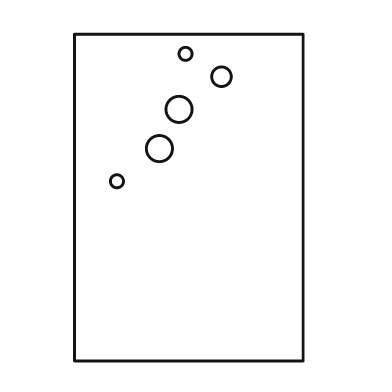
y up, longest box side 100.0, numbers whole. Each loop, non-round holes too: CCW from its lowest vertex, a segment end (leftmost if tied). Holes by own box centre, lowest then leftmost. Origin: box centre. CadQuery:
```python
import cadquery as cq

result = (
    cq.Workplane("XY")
    .moveTo(-35.0, -50.0)
    .lineTo(35.0, -50.0)
    .lineTo(35.0, 50.0)
    .lineTo(-35.0, 50.0)
    .close()
    .moveTo(-22.0, 5.0)
    .circle(2.0)
    .moveTo(-9.0, 15.0)
    .circle(4.0)
    .moveTo(-3.0, 27.0)
    .circle(4.0)
    .moveTo(10.0, 37.0)
    .circle(3.0)
    .moveTo(-1.0, 44.0)
    .circle(2.0)
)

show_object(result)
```